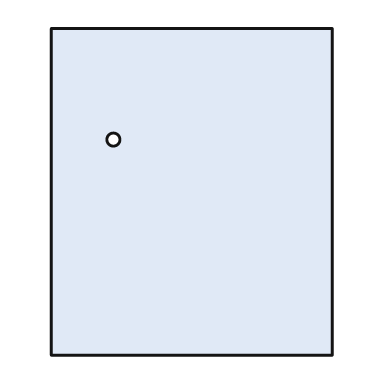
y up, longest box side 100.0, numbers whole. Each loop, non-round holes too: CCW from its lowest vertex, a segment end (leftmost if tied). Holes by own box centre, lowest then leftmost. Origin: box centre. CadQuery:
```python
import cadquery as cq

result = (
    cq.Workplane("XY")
    .moveTo(-43.0, -50.0)
    .lineTo(43.0, -50.0)
    .lineTo(43.0, 50.0)
    .lineTo(-43.0, 50.0)
    .close()
    .moveTo(-24.0, 16.0)
    .circle(2.0)
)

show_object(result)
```